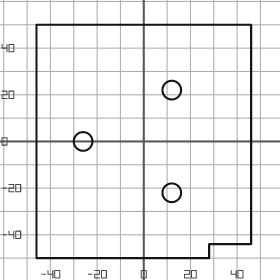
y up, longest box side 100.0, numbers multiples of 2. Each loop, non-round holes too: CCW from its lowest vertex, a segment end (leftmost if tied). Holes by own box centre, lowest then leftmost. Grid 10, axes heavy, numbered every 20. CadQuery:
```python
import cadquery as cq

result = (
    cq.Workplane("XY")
    .moveTo(-46.0, -50.0)
    .lineTo(28.0, -50.0)
    .lineTo(28.0, -44.0)
    .lineTo(46.0, -44.0)
    .lineTo(46.0, 50.0)
    .lineTo(-46.0, 50.0)
    .close()
    .moveTo(12.0, -22.0)
    .circle(4.0)
    .moveTo(-26.0, 0.0)
    .circle(4.0)
    .moveTo(12.0, 22.0)
    .circle(4.0)
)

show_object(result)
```